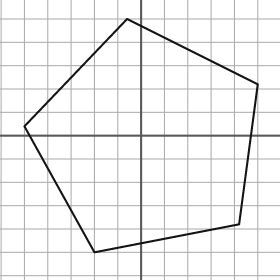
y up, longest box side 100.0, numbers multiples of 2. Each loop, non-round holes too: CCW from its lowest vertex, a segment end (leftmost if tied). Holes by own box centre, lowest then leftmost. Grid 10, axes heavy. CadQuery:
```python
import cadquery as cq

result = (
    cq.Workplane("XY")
    .moveTo(-20.0, -50.0)
    .lineTo(42.0, -38.0)
    .lineTo(50.0, 22.0)
    .lineTo(-6.0, 50.0)
    .lineTo(-50.0, 4.0)
    .close()
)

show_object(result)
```